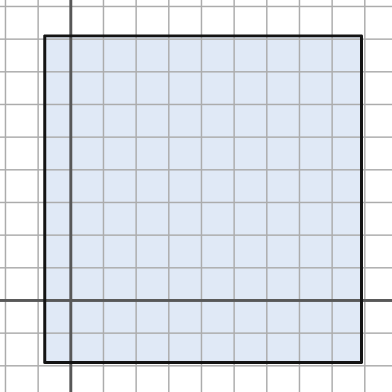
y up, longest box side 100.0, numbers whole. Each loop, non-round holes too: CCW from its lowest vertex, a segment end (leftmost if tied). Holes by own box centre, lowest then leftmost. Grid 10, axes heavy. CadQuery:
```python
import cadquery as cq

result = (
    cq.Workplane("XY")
    .moveTo(-8.0, -19.0)
    .lineTo(89.0, -19.0)
    .lineTo(89.0, 81.0)
    .lineTo(-8.0, 81.0)
    .close()
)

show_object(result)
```